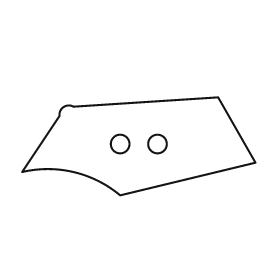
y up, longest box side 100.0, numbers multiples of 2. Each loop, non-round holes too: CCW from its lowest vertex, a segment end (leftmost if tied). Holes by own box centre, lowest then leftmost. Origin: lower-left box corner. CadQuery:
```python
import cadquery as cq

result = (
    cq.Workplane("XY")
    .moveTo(42.0, 0.0)
    .lineTo(100.0, 14.0)
    .lineTo(84.0, 42.0)
    .lineTo(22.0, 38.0)
    .threePointArc((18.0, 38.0), (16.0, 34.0))
    .lineTo(0.0, 10.0)
    .threePointArc((22.0, 10.0), (42.0, 0.0))
    .close()
    .moveTo(42.0, 22.0)
    .circle(4.0)
    .moveTo(58.0, 22.0)
    .circle(4.0)
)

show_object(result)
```